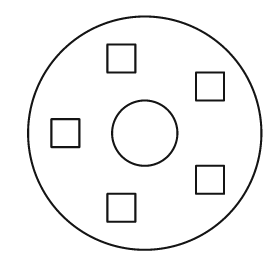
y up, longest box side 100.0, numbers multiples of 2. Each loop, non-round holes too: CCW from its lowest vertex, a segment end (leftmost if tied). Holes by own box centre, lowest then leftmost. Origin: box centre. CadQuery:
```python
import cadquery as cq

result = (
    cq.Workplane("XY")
    .moveTo(0.0, 0.0)
    .circle(50.0)
    .moveTo(-16.0, -38.0)
    .lineTo(-4.0, -38.0)
    .lineTo(-4.0, -26.0)
    .lineTo(-16.0, -26.0)
    .close()
    .moveTo(22.0, -26.0)
    .lineTo(34.0, -26.0)
    .lineTo(34.0, -14.0)
    .lineTo(22.0, -14.0)
    .close()
    .moveTo(-40.0, -6.0)
    .lineTo(-28.0, -6.0)
    .lineTo(-28.0, 6.0)
    .lineTo(-40.0, 6.0)
    .close()
    .moveTo(0.0, 0.0)
    .circle(14.0)
    .moveTo(22.0, 14.0)
    .lineTo(34.0, 14.0)
    .lineTo(34.0, 26.0)
    .lineTo(22.0, 26.0)
    .close()
    .moveTo(-16.0, 26.0)
    .lineTo(-4.0, 26.0)
    .lineTo(-4.0, 38.0)
    .lineTo(-16.0, 38.0)
    .close()
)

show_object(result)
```